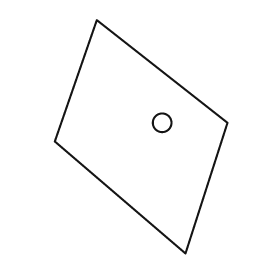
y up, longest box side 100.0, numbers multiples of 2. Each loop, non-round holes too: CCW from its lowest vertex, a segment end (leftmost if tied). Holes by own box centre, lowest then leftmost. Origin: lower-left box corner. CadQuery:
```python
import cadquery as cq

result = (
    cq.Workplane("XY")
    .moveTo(56.0, 0.0)
    .lineTo(74.0, 56.0)
    .lineTo(18.0, 100.0)
    .lineTo(0.0, 48.0)
    .close()
    .moveTo(46.0, 56.0)
    .circle(4.0)
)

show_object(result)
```